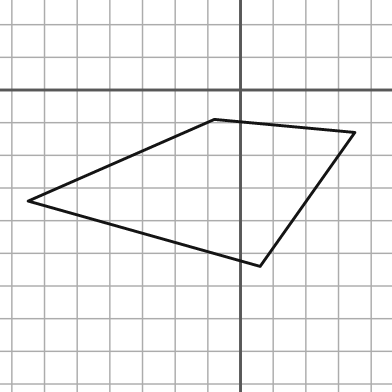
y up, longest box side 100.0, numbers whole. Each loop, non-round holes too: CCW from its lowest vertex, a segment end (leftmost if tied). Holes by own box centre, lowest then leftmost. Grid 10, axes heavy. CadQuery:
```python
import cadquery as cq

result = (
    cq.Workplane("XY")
    .moveTo(6.0, -54.0)
    .lineTo(35.0, -13.0)
    .lineTo(-8.0, -9.0)
    .lineTo(-65.0, -34.0)
    .close()
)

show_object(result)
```